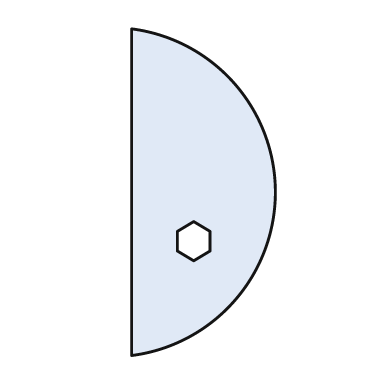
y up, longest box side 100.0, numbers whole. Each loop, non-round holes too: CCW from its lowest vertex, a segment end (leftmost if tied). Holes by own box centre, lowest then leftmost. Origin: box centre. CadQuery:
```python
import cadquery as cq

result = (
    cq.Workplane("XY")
    .moveTo(-22.0, -50.0)
    .threePointArc((22.0, 0.0), (-22.0, 50.0))
    .close()
    .moveTo(-3.0, -21.0)
    .lineTo(2.0, -18.0)
    .lineTo(2.0, -12.0)
    .lineTo(-3.0, -9.0)
    .lineTo(-8.0, -12.0)
    .lineTo(-8.0, -18.0)
    .close()
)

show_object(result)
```